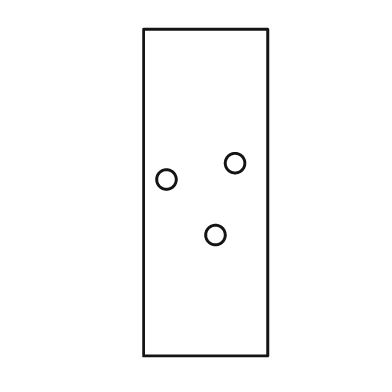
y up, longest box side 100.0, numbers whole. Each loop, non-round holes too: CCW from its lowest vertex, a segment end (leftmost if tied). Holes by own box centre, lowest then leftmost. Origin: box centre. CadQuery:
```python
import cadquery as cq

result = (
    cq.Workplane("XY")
    .moveTo(-19.0, -50.0)
    .lineTo(19.0, -50.0)
    .lineTo(19.0, 50.0)
    .lineTo(-19.0, 50.0)
    .close()
    .moveTo(3.0, -13.0)
    .circle(3.0)
    .moveTo(-12.0, 4.0)
    .circle(3.0)
    .moveTo(9.0, 9.0)
    .circle(3.0)
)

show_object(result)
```